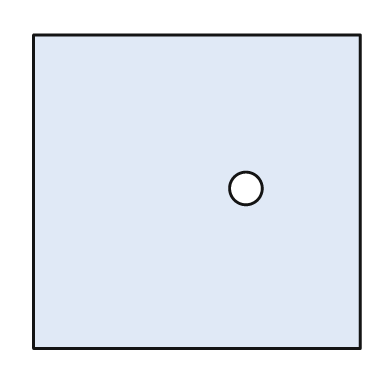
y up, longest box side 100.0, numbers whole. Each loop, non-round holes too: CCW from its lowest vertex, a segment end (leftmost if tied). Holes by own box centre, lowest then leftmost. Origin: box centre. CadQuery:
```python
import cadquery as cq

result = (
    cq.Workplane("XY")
    .moveTo(-50.0, -48.0)
    .lineTo(50.0, -48.0)
    .lineTo(50.0, 48.0)
    .lineTo(-50.0, 48.0)
    .close()
    .moveTo(15.0, 1.0)
    .circle(5.0)
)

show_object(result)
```